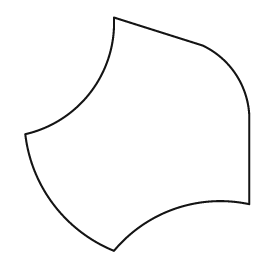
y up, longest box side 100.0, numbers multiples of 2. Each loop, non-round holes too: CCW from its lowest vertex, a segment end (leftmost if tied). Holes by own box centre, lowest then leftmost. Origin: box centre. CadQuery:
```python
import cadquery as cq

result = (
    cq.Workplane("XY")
    .moveTo(-10.0, -50.0)
    .threePointArc((16.0, -32.0), (48.0, -30.0))
    .lineTo(48.0, 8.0)
    .threePointArc((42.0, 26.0), (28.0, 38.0))
    .lineTo(-10.0, 50.0)
    .threePointArc((-20.0, 18.0), (-48.0, 0.0))
    .threePointArc((-36.0, -30.0), (-10.0, -50.0))
    .close()
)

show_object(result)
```